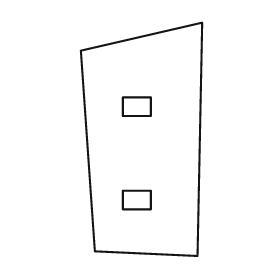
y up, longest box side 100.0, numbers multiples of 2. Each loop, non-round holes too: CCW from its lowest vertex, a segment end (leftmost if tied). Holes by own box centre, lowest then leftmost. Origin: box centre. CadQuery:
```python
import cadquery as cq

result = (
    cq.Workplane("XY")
    .moveTo(24.0, -50.0)
    .lineTo(26.0, 50.0)
    .lineTo(-26.0, 38.0)
    .lineTo(-20.0, -48.0)
    .close()
    .moveTo(-8.0, -30.0)
    .lineTo(4.0, -30.0)
    .lineTo(4.0, -22.0)
    .lineTo(-8.0, -22.0)
    .close()
    .moveTo(-8.0, 10.0)
    .lineTo(4.0, 10.0)
    .lineTo(4.0, 18.0)
    .lineTo(-8.0, 18.0)
    .close()
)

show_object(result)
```